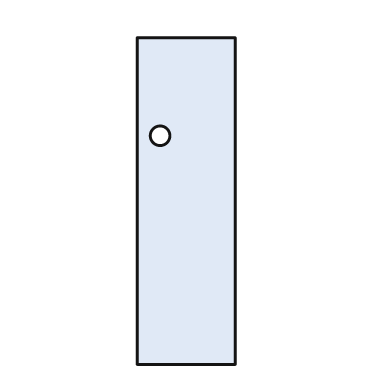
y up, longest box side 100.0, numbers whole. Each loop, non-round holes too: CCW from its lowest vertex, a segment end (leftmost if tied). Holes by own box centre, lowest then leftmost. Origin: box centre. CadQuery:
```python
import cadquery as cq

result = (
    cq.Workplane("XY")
    .moveTo(-15.0, -50.0)
    .lineTo(15.0, -50.0)
    .lineTo(15.0, 50.0)
    .lineTo(-15.0, 50.0)
    .close()
    .moveTo(-8.0, 20.0)
    .circle(3.0)
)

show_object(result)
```